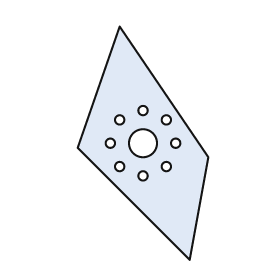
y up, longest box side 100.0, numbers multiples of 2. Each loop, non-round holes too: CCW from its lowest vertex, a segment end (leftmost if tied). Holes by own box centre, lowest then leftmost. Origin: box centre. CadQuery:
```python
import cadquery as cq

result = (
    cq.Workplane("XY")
    .moveTo(20.0, -50.0)
    .lineTo(28.0, -6.0)
    .lineTo(-10.0, 50.0)
    .lineTo(-28.0, -2.0)
    .close()
    .moveTo(0.0, -14.0)
    .circle(2.0)
    .moveTo(-10.0, -10.0)
    .circle(2.0)
    .moveTo(10.0, -10.0)
    .circle(2.0)
    .moveTo(-14.0, 0.0)
    .circle(2.0)
    .moveTo(0.0, 0.0)
    .circle(6.0)
    .moveTo(14.0, 0.0)
    .circle(2.0)
    .moveTo(-10.0, 10.0)
    .circle(2.0)
    .moveTo(10.0, 10.0)
    .circle(2.0)
    .moveTo(0.0, 14.0)
    .circle(2.0)
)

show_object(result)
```